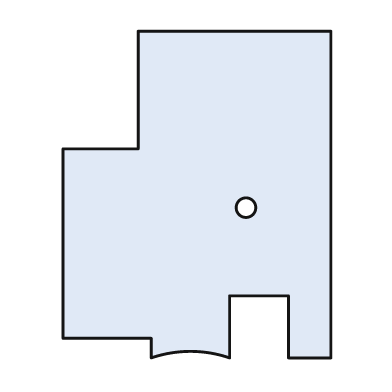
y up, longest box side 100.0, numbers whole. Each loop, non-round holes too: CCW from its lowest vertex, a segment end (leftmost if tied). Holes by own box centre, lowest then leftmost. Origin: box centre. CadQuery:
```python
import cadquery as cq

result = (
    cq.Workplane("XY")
    .moveTo(-14.0, -50.0)
    .threePointArc((-2.0, -48.0), (10.0, -50.0))
    .lineTo(10.0, -31.0)
    .lineTo(28.0, -31.0)
    .lineTo(28.0, -50.0)
    .lineTo(41.0, -50.0)
    .lineTo(41.0, 50.0)
    .lineTo(-18.0, 50.0)
    .lineTo(-18.0, 14.0)
    .lineTo(-41.0, 14.0)
    .lineTo(-41.0, -44.0)
    .lineTo(-14.0, -44.0)
    .close()
    .moveTo(15.0, -4.0)
    .circle(3.0)
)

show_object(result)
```